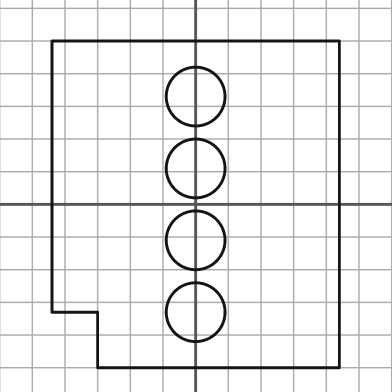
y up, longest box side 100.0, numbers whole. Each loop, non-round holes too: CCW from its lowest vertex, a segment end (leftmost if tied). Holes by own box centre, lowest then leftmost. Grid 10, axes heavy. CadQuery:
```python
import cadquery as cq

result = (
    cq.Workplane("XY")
    .moveTo(-30.0, -50.0)
    .lineTo(44.0, -50.0)
    .lineTo(44.0, 50.0)
    .lineTo(-44.0, 50.0)
    .lineTo(-44.0, -33.0)
    .lineTo(-30.0, -33.0)
    .close()
    .moveTo(0.0, -33.0)
    .circle(9.0)
    .moveTo(0.0, -11.0)
    .circle(9.0)
    .moveTo(0.0, 11.0)
    .circle(9.0)
    .moveTo(0.0, 33.0)
    .circle(9.0)
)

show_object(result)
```